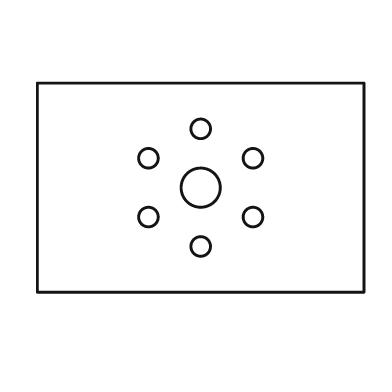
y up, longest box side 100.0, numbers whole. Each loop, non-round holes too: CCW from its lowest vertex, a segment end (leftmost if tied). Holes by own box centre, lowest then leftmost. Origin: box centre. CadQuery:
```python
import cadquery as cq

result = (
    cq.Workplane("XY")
    .moveTo(-50.0, -32.0)
    .lineTo(50.0, -32.0)
    .lineTo(50.0, 32.0)
    .lineTo(-50.0, 32.0)
    .close()
    .moveTo(0.0, -18.0)
    .circle(3.0)
    .moveTo(-16.0, -9.0)
    .circle(3.0)
    .moveTo(16.0, -9.0)
    .circle(3.0)
    .moveTo(0.0, 0.0)
    .circle(6.0)
    .moveTo(-16.0, 9.0)
    .circle(3.0)
    .moveTo(16.0, 9.0)
    .circle(3.0)
    .moveTo(0.0, 18.0)
    .circle(3.0)
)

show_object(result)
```